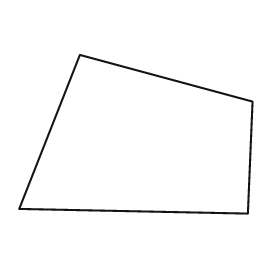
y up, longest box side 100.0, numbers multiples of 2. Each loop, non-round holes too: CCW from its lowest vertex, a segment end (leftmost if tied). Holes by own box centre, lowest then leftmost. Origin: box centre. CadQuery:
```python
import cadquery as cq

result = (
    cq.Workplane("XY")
    .moveTo(48.0, -34.0)
    .lineTo(50.0, 14.0)
    .lineTo(-24.0, 34.0)
    .lineTo(-50.0, -32.0)
    .close()
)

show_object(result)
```